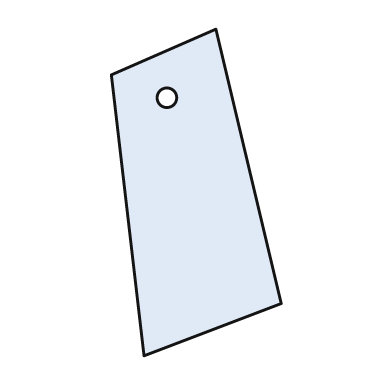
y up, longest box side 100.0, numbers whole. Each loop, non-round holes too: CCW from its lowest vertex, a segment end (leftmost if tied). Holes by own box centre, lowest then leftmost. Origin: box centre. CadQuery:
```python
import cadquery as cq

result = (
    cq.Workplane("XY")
    .moveTo(-16.0, -50.0)
    .lineTo(26.0, -34.0)
    .lineTo(6.0, 50.0)
    .lineTo(-26.0, 36.0)
    .close()
    .moveTo(-9.0, 29.0)
    .circle(3.0)
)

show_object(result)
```